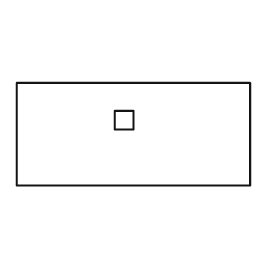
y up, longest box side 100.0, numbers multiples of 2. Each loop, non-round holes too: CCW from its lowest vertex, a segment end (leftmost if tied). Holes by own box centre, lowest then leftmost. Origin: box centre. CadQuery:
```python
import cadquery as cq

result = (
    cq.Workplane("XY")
    .moveTo(-50.0, -22.0)
    .lineTo(50.0, -22.0)
    .lineTo(50.0, 22.0)
    .lineTo(-50.0, 22.0)
    .close()
    .moveTo(-8.0, 2.0)
    .lineTo(0.0, 2.0)
    .lineTo(0.0, 10.0)
    .lineTo(-8.0, 10.0)
    .close()
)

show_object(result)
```